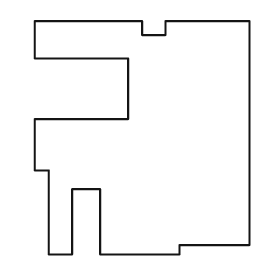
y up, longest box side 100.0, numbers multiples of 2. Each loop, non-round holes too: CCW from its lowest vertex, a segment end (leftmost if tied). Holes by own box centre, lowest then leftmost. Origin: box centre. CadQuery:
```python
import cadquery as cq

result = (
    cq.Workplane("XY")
    .moveTo(-40.0, -50.0)
    .lineTo(-30.0, -50.0)
    .lineTo(-30.0, -22.0)
    .lineTo(-18.0, -22.0)
    .lineTo(-18.0, -50.0)
    .lineTo(16.0, -50.0)
    .lineTo(16.0, -46.0)
    .lineTo(46.0, -46.0)
    .lineTo(46.0, 50.0)
    .lineTo(10.0, 50.0)
    .lineTo(10.0, 44.0)
    .lineTo(0.0, 44.0)
    .lineTo(0.0, 50.0)
    .lineTo(-46.0, 50.0)
    .lineTo(-46.0, 34.0)
    .lineTo(-6.0, 34.0)
    .lineTo(-6.0, 8.0)
    .lineTo(-46.0, 8.0)
    .lineTo(-46.0, -14.0)
    .lineTo(-40.0, -14.0)
    .close()
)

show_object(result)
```